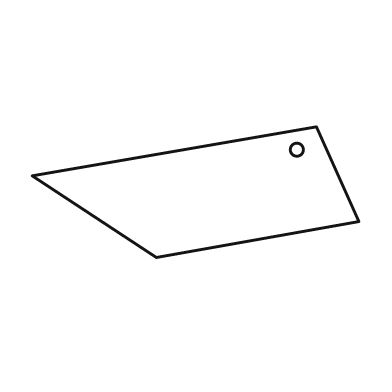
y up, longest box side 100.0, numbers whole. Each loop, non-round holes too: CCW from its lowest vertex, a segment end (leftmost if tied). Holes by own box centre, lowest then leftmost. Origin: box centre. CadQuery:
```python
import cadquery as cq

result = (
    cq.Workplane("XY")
    .moveTo(-12.0, -20.0)
    .lineTo(50.0, -9.0)
    .lineTo(37.0, 20.0)
    .lineTo(-50.0, 5.0)
    .close()
    .moveTo(31.0, 13.0)
    .circle(2.0)
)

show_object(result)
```